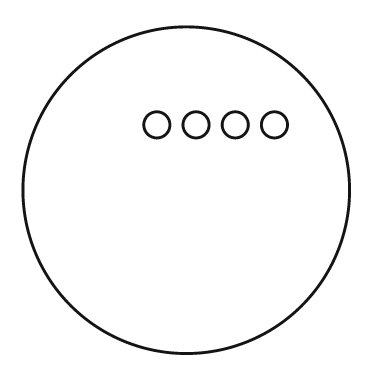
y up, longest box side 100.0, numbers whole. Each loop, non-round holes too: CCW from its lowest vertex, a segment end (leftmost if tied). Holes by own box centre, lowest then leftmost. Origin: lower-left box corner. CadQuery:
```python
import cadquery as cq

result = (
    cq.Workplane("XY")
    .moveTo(50.0, 50.0)
    .circle(50.0)
    .moveTo(41.0, 70.0)
    .circle(4.0)
    .moveTo(53.0, 70.0)
    .circle(4.0)
    .moveTo(65.0, 70.0)
    .circle(4.0)
    .moveTo(77.0, 70.0)
    .circle(4.0)
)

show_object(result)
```